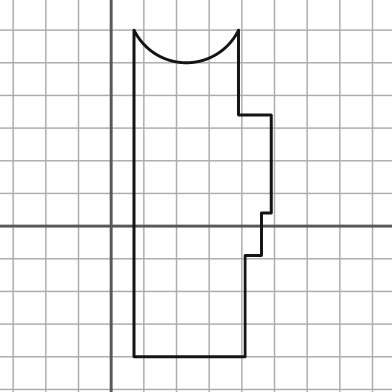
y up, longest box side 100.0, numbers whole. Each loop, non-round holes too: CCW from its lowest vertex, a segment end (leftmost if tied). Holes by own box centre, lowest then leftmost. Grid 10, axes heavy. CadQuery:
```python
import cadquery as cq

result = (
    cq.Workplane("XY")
    .moveTo(7.0, -40.0)
    .lineTo(41.0, -40.0)
    .lineTo(41.0, -9.0)
    .lineTo(46.0, -9.0)
    .lineTo(46.0, 4.0)
    .lineTo(49.0, 4.0)
    .lineTo(49.0, 34.0)
    .lineTo(39.0, 34.0)
    .lineTo(39.0, 60.0)
    .threePointArc((23.0, 50.0), (7.0, 60.0))
    .close()
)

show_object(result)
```